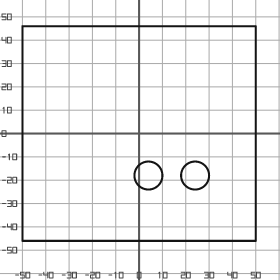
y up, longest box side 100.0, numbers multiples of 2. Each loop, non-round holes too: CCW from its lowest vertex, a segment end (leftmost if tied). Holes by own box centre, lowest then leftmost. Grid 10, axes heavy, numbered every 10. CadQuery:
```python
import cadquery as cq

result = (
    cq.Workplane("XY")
    .moveTo(-50.0, -46.0)
    .lineTo(50.0, -46.0)
    .lineTo(50.0, 46.0)
    .lineTo(-50.0, 46.0)
    .close()
    .moveTo(4.0, -18.0)
    .circle(6.0)
    .moveTo(24.0, -18.0)
    .circle(6.0)
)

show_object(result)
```